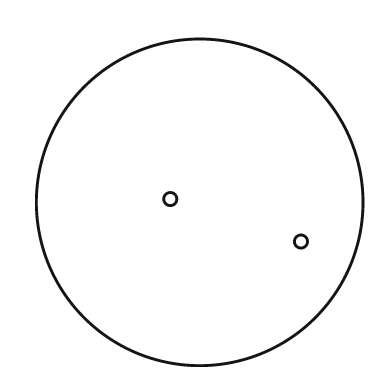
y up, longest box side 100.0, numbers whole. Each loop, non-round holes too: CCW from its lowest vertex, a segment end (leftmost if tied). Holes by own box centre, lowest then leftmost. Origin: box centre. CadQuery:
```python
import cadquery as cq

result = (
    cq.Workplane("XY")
    .moveTo(0.0, 0.0)
    .circle(50.0)
    .moveTo(31.0, -12.0)
    .circle(2.0)
    .moveTo(-9.0, 1.0)
    .circle(2.0)
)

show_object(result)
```